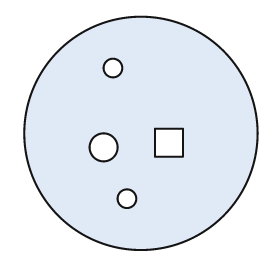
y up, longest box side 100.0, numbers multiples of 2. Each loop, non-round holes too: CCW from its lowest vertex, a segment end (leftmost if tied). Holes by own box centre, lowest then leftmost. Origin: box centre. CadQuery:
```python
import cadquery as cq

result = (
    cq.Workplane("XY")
    .moveTo(0.0, 0.0)
    .circle(50.0)
    .moveTo(-6.0, -28.0)
    .circle(4.0)
    .moveTo(-16.0, -6.0)
    .circle(6.0)
    .moveTo(6.0, -10.0)
    .lineTo(18.0, -10.0)
    .lineTo(18.0, 2.0)
    .lineTo(6.0, 2.0)
    .close()
    .moveTo(-12.0, 28.0)
    .circle(4.0)
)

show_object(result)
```